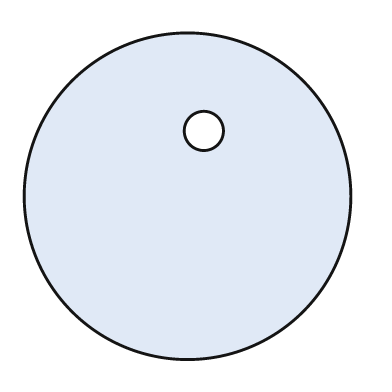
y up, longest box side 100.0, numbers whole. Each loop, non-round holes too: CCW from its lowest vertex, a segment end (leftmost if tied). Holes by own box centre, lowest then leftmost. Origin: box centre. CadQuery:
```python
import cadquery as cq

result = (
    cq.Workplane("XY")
    .moveTo(0.0, 0.0)
    .circle(50.0)
    .moveTo(5.0, 20.0)
    .circle(6.0)
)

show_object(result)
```